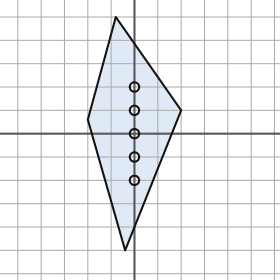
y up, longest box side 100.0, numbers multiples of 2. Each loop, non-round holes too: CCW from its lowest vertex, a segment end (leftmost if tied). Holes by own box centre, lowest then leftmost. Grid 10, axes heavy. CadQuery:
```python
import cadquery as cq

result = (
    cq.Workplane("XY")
    .moveTo(-4.0, -50.0)
    .lineTo(20.0, 10.0)
    .lineTo(-8.0, 50.0)
    .lineTo(-20.0, 6.0)
    .close()
    .moveTo(0.0, -20.0)
    .circle(2.0)
    .moveTo(0.0, -10.0)
    .circle(2.0)
    .moveTo(0.0, 0.0)
    .circle(2.0)
    .moveTo(0.0, 10.0)
    .circle(2.0)
    .moveTo(0.0, 20.0)
    .circle(2.0)
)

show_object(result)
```